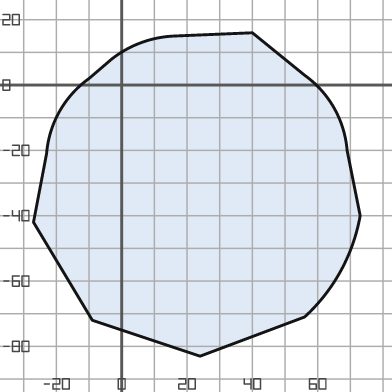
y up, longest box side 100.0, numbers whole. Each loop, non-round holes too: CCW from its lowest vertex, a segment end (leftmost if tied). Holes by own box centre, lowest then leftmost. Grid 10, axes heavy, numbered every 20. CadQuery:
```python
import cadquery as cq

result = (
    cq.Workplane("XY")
    .moveTo(24.0, -83.0)
    .lineTo(56.0, -71.0)
    .threePointArc((67.0, -57.0), (73.0, -40.0))
    .lineTo(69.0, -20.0)
    .threePointArc((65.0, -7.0), (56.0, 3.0))
    .lineTo(40.0, 16.0)
    .lineTo(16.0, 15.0)
    .threePointArc((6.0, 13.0), (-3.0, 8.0))
    .lineTo(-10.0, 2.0)
    .threePointArc((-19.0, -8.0), (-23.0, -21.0))
    .lineTo(-27.0, -42.0)
    .lineTo(-9.0, -72.0)
    .close()
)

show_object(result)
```